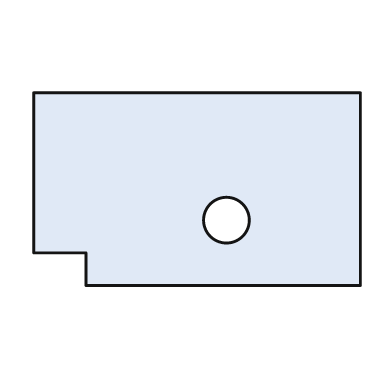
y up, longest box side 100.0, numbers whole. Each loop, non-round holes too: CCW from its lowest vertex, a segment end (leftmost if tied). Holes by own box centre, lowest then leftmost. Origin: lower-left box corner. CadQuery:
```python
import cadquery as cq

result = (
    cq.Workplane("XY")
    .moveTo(16.0, 0.0)
    .lineTo(100.0, 0.0)
    .lineTo(100.0, 59.0)
    .lineTo(0.0, 59.0)
    .lineTo(0.0, 10.0)
    .lineTo(16.0, 10.0)
    .close()
    .moveTo(59.0, 20.0)
    .circle(7.0)
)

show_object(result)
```